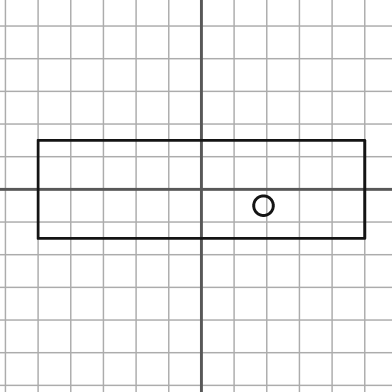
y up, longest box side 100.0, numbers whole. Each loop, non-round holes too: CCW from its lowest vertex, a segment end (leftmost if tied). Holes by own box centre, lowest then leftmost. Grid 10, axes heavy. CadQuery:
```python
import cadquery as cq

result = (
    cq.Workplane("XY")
    .moveTo(-50.0, -15.0)
    .lineTo(50.0, -15.0)
    .lineTo(50.0, 15.0)
    .lineTo(-50.0, 15.0)
    .close()
    .moveTo(19.0, -5.0)
    .circle(3.0)
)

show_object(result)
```